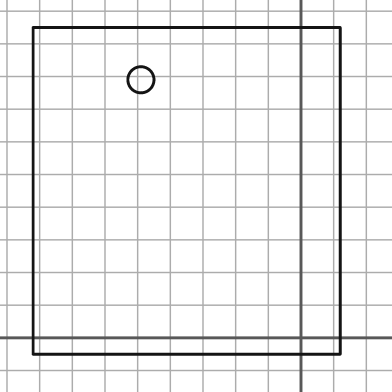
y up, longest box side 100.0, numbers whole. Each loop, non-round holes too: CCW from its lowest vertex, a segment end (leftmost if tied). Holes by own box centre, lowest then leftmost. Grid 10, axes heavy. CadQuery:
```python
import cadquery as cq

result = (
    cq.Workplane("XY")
    .moveTo(-82.0, -5.0)
    .lineTo(12.0, -5.0)
    .lineTo(12.0, 95.0)
    .lineTo(-82.0, 95.0)
    .close()
    .moveTo(-49.0, 79.0)
    .circle(4.0)
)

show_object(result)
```